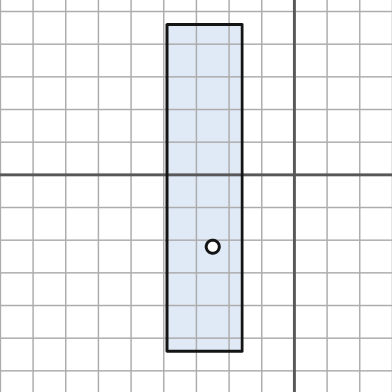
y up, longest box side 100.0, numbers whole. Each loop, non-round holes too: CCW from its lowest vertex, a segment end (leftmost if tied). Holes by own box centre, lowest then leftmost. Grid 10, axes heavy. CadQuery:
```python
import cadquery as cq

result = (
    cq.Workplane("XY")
    .moveTo(-39.0, -54.0)
    .lineTo(-16.0, -54.0)
    .lineTo(-16.0, 46.0)
    .lineTo(-39.0, 46.0)
    .close()
    .moveTo(-25.0, -22.0)
    .circle(2.0)
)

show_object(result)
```